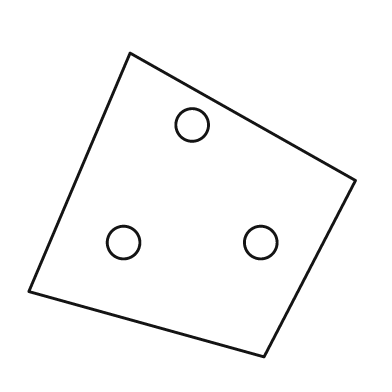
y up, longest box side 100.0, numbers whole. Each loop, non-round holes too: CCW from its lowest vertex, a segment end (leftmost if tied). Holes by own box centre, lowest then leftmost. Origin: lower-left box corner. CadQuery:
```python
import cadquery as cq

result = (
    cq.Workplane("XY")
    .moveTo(72.0, 0.0)
    .lineTo(100.0, 54.0)
    .lineTo(31.0, 93.0)
    .lineTo(0.0, 20.0)
    .close()
    .moveTo(29.0, 35.0)
    .circle(5.0)
    .moveTo(71.0, 35.0)
    .circle(5.0)
    .moveTo(50.0, 71.0)
    .circle(5.0)
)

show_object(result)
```